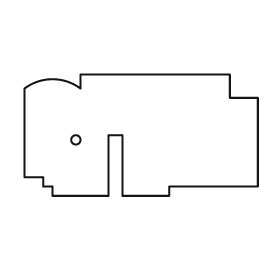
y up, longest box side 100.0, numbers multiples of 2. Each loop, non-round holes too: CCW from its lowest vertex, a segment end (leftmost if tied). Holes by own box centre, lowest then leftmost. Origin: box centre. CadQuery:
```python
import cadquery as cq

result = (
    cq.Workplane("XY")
    .moveTo(-38.0, -26.0)
    .lineTo(-14.0, -26.0)
    .lineTo(-14.0, 0.0)
    .lineTo(-8.0, 0.0)
    .lineTo(-8.0, -26.0)
    .lineTo(12.0, -26.0)
    .lineTo(12.0, -22.0)
    .lineTo(50.0, -22.0)
    .lineTo(50.0, 16.0)
    .lineTo(38.0, 16.0)
    .lineTo(38.0, 26.0)
    .lineTo(-26.0, 26.0)
    .lineTo(-26.0, 20.0)
    .threePointArc((-38.0, 24.0), (-50.0, 20.0))
    .lineTo(-50.0, -18.0)
    .lineTo(-42.0, -18.0)
    .lineTo(-42.0, -22.0)
    .lineTo(-38.0, -22.0)
    .close()
    .moveTo(-28.0, -2.0)
    .circle(2.0)
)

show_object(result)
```